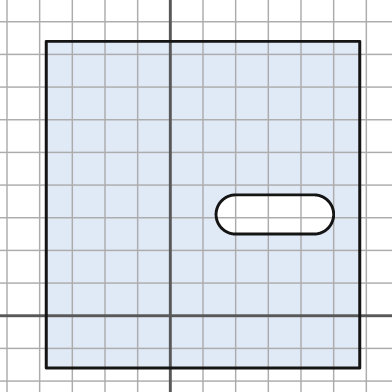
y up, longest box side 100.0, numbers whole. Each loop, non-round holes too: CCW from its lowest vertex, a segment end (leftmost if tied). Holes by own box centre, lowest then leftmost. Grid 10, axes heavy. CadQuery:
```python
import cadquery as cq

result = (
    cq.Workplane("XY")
    .moveTo(-38.0, -16.0)
    .lineTo(58.0, -16.0)
    .lineTo(58.0, 84.0)
    .lineTo(-38.0, 84.0)
    .close()
    .moveTo(20.0, 25.0)
    .lineTo(44.0, 25.0)
    .threePointArc((50.0, 31.0), (44.0, 37.0))
    .lineTo(20.0, 37.0)
    .threePointArc((14.0, 31.0), (20.0, 25.0))
    .close()
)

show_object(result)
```